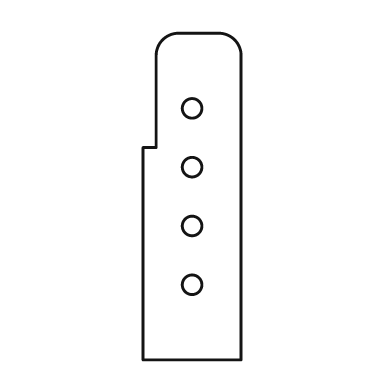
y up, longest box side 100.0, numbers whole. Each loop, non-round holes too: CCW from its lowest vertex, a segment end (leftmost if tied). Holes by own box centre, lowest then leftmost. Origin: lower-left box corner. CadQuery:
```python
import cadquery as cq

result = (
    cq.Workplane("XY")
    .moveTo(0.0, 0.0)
    .lineTo(30.0, 0.0)
    .lineTo(30.0, 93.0)
    .threePointArc((28.0, 98.0), (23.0, 100.0))
    .lineTo(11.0, 100.0)
    .threePointArc((6.0, 98.0), (4.0, 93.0))
    .lineTo(4.0, 65.0)
    .lineTo(0.0, 65.0)
    .close()
    .moveTo(15.0, 23.0)
    .circle(3.0)
    .moveTo(15.0, 41.0)
    .circle(3.0)
    .moveTo(15.0, 59.0)
    .circle(3.0)
    .moveTo(15.0, 77.0)
    .circle(3.0)
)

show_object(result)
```